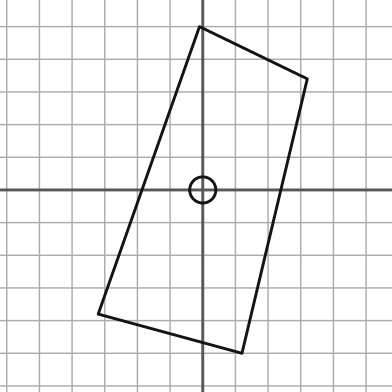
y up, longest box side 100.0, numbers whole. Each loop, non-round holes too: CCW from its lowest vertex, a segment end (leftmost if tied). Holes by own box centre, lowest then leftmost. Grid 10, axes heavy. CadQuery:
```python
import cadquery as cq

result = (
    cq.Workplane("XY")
    .moveTo(12.0, -50.0)
    .lineTo(32.0, 34.0)
    .lineTo(-1.0, 50.0)
    .lineTo(-32.0, -38.0)
    .close()
    .moveTo(0.0, 0.0)
    .circle(4.0)
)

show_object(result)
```